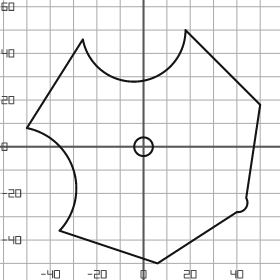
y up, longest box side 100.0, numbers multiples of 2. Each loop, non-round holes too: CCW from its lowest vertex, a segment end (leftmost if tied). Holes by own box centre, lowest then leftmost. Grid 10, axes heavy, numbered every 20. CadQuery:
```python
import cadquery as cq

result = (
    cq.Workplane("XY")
    .moveTo(6.0, -50.0)
    .lineTo(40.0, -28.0)
    .threePointArc((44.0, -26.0), (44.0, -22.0))
    .lineTo(50.0, 18.0)
    .lineTo(18.0, 50.0)
    .threePointArc((-2.0, 28.0), (-26.0, 46.0))
    .lineTo(-50.0, 8.0)
    .threePointArc((-30.0, -10.0), (-36.0, -36.0))
    .close()
    .moveTo(0.0, 0.0)
    .circle(4.0)
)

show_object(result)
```